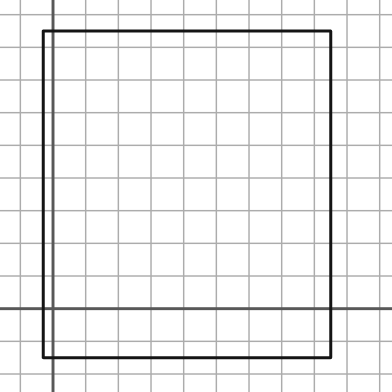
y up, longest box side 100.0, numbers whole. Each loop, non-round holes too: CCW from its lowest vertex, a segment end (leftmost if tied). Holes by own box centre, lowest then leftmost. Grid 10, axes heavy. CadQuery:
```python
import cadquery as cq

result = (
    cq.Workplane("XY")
    .moveTo(-3.0, -15.0)
    .lineTo(85.0, -15.0)
    .lineTo(85.0, 85.0)
    .lineTo(-3.0, 85.0)
    .close()
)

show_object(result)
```